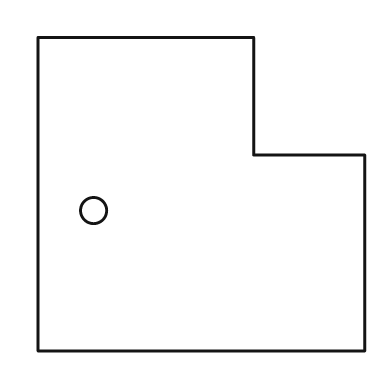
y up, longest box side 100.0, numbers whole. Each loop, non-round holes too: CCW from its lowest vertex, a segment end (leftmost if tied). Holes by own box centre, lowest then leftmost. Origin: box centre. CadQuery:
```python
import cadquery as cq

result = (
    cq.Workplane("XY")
    .moveTo(-50.0, -48.0)
    .lineTo(50.0, -48.0)
    .lineTo(50.0, 12.0)
    .lineTo(16.0, 12.0)
    .lineTo(16.0, 48.0)
    .lineTo(-50.0, 48.0)
    .close()
    .moveTo(-33.0, -5.0)
    .circle(4.0)
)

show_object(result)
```